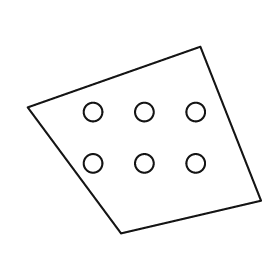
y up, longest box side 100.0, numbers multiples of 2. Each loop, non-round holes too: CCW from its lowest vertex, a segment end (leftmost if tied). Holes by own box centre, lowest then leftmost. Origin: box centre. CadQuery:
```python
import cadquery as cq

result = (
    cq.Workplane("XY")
    .moveTo(-10.0, -40.0)
    .lineTo(50.0, -26.0)
    .lineTo(24.0, 40.0)
    .lineTo(-50.0, 14.0)
    .close()
    .moveTo(-22.0, -10.0)
    .circle(4.0)
    .moveTo(0.0, -10.0)
    .circle(4.0)
    .moveTo(22.0, -10.0)
    .circle(4.0)
    .moveTo(-22.0, 12.0)
    .circle(4.0)
    .moveTo(0.0, 12.0)
    .circle(4.0)
    .moveTo(22.0, 12.0)
    .circle(4.0)
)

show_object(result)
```